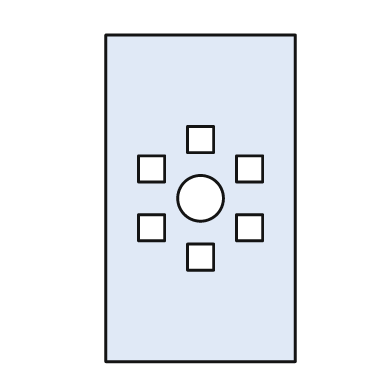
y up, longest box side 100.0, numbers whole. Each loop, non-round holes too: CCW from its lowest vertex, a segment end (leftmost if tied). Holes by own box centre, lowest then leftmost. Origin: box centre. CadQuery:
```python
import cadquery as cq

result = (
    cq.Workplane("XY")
    .moveTo(-29.0, -50.0)
    .lineTo(29.0, -50.0)
    .lineTo(29.0, 50.0)
    .lineTo(-29.0, 50.0)
    .close()
    .moveTo(-4.0, -22.0)
    .lineTo(4.0, -22.0)
    .lineTo(4.0, -14.0)
    .lineTo(-4.0, -14.0)
    .close()
    .moveTo(-19.0, -13.0)
    .lineTo(-11.0, -13.0)
    .lineTo(-11.0, -5.0)
    .lineTo(-19.0, -5.0)
    .close()
    .moveTo(11.0, -13.0)
    .lineTo(19.0, -13.0)
    .lineTo(19.0, -5.0)
    .lineTo(11.0, -5.0)
    .close()
    .moveTo(0.0, 0.0)
    .circle(7.0)
    .moveTo(-19.0, 5.0)
    .lineTo(-11.0, 5.0)
    .lineTo(-11.0, 13.0)
    .lineTo(-19.0, 13.0)
    .close()
    .moveTo(11.0, 5.0)
    .lineTo(19.0, 5.0)
    .lineTo(19.0, 13.0)
    .lineTo(11.0, 13.0)
    .close()
    .moveTo(-4.0, 14.0)
    .lineTo(4.0, 14.0)
    .lineTo(4.0, 22.0)
    .lineTo(-4.0, 22.0)
    .close()
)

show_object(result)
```